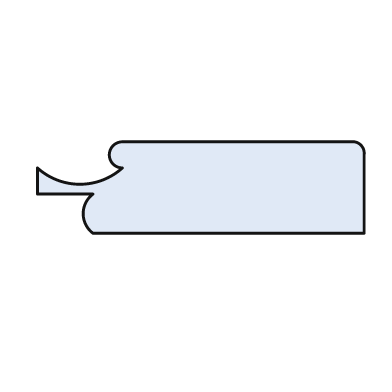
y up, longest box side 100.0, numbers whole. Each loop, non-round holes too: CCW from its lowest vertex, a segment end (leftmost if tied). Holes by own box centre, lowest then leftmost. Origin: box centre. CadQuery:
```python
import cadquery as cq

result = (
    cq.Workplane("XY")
    .moveTo(-33.0, -14.0)
    .lineTo(50.0, -14.0)
    .lineTo(50.0, 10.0)
    .threePointArc((49.0, 13.0), (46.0, 14.0))
    .lineTo(-24.0, 14.0)
    .threePointArc((-28.0, 10.0), (-24.0, 6.0))
    .threePointArc((-37.0, 1.0), (-50.0, 6.0))
    .lineTo(-50.0, -2.0)
    .lineTo(-33.0, -2.0)
    .threePointArc((-36.0, -8.0), (-33.0, -14.0))
    .close()
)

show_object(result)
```